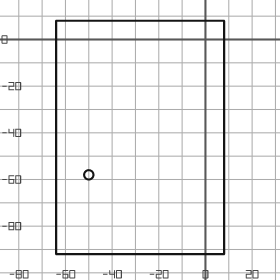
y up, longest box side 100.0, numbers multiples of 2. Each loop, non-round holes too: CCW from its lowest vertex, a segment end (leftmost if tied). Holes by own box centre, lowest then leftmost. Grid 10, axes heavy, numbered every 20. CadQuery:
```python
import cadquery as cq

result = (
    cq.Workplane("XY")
    .moveTo(-64.0, -92.0)
    .lineTo(8.0, -92.0)
    .lineTo(8.0, 8.0)
    .lineTo(-64.0, 8.0)
    .close()
    .moveTo(-50.0, -58.0)
    .circle(2.0)
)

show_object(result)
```